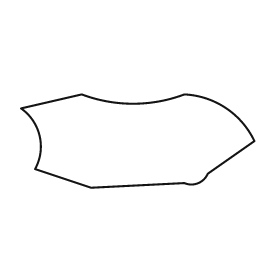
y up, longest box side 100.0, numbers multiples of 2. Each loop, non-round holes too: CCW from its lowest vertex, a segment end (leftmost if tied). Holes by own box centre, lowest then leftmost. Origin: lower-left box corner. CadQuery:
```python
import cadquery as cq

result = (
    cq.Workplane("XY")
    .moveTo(30.0, 0.0)
    .lineTo(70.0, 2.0)
    .threePointArc((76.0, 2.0), (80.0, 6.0))
    .lineTo(100.0, 20.0)
    .threePointArc((88.0, 34.0), (70.0, 40.0))
    .threePointArc((48.0, 36.0), (26.0, 40.0))
    .lineTo(0.0, 34.0)
    .threePointArc((8.0, 22.0), (6.0, 8.0))
    .close()
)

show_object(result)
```